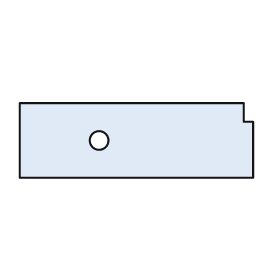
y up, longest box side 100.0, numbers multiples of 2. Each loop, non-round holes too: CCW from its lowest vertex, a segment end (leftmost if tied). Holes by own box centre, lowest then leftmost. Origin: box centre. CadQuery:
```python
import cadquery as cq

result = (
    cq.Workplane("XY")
    .moveTo(-50.0, -16.0)
    .lineTo(50.0, -16.0)
    .lineTo(50.0, 8.0)
    .lineTo(46.0, 8.0)
    .lineTo(46.0, 16.0)
    .lineTo(-50.0, 16.0)
    .close()
    .moveTo(-16.0, 0.0)
    .circle(4.0)
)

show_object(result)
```